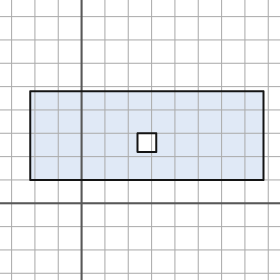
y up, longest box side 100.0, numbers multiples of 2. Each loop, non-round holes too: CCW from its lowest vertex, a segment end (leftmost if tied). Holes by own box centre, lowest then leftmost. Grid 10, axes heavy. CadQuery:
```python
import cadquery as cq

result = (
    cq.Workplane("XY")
    .moveTo(-22.0, 10.0)
    .lineTo(78.0, 10.0)
    .lineTo(78.0, 48.0)
    .lineTo(-22.0, 48.0)
    .close()
    .moveTo(24.0, 22.0)
    .lineTo(32.0, 22.0)
    .lineTo(32.0, 30.0)
    .lineTo(24.0, 30.0)
    .close()
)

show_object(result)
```